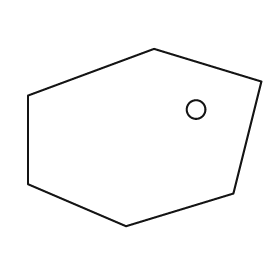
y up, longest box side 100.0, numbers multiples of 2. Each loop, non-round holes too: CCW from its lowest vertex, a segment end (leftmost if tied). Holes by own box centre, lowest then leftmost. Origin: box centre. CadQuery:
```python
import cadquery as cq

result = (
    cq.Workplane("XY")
    .moveTo(-8.0, -38.0)
    .lineTo(38.0, -24.0)
    .lineTo(50.0, 24.0)
    .lineTo(4.0, 38.0)
    .lineTo(-50.0, 18.0)
    .lineTo(-50.0, -20.0)
    .close()
    .moveTo(22.0, 12.0)
    .circle(4.0)
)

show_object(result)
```